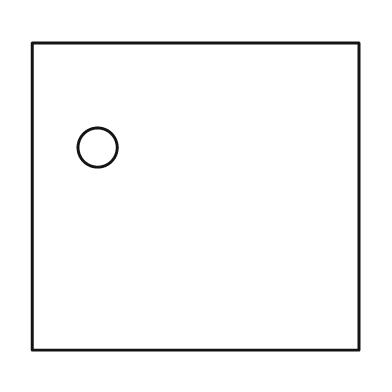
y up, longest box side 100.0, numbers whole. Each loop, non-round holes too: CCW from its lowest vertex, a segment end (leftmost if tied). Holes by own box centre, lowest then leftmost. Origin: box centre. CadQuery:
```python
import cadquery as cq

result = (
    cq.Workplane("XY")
    .moveTo(-50.0, -47.0)
    .lineTo(50.0, -47.0)
    .lineTo(50.0, 47.0)
    .lineTo(-50.0, 47.0)
    .close()
    .moveTo(-30.0, 15.0)
    .circle(6.0)
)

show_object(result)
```